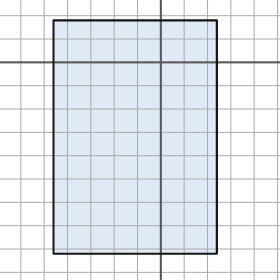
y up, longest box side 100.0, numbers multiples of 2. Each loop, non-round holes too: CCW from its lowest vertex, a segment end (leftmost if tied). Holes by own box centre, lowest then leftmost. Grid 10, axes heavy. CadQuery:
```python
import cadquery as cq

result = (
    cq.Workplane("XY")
    .moveTo(-46.0, -82.0)
    .lineTo(24.0, -82.0)
    .lineTo(24.0, 18.0)
    .lineTo(-46.0, 18.0)
    .close()
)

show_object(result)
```